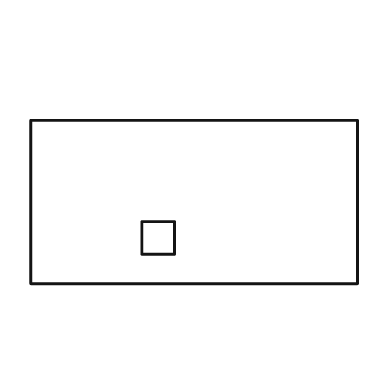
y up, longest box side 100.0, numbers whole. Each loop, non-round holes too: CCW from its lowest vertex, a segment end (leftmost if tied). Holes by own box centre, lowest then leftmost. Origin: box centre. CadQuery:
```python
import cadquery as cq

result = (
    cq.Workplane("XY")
    .moveTo(-50.0, -25.0)
    .lineTo(50.0, -25.0)
    .lineTo(50.0, 25.0)
    .lineTo(-50.0, 25.0)
    .close()
    .moveTo(-16.0, -16.0)
    .lineTo(-6.0, -16.0)
    .lineTo(-6.0, -6.0)
    .lineTo(-16.0, -6.0)
    .close()
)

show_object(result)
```